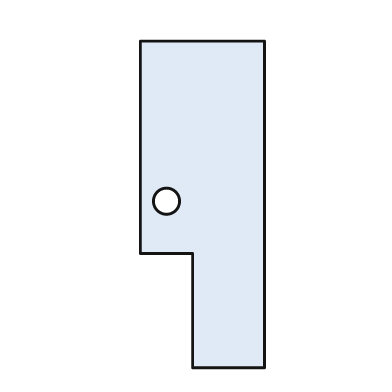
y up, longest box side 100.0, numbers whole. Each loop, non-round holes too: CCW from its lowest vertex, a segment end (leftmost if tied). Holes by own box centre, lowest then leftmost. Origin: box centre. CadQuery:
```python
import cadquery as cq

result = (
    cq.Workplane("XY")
    .moveTo(-3.0, -50.0)
    .lineTo(19.0, -50.0)
    .lineTo(19.0, 50.0)
    .lineTo(-19.0, 50.0)
    .lineTo(-19.0, -15.0)
    .lineTo(-3.0, -15.0)
    .close()
    .moveTo(-11.0, 1.0)
    .circle(4.0)
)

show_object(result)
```